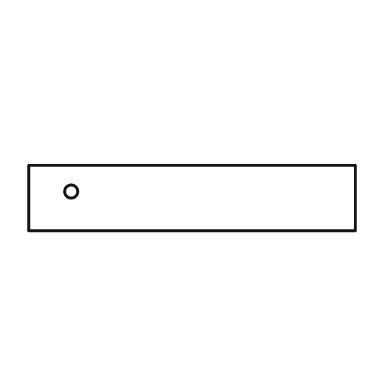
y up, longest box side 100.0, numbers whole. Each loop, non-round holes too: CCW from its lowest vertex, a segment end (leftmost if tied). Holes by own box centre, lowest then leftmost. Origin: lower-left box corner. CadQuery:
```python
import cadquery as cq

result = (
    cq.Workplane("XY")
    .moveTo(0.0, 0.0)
    .lineTo(100.0, 0.0)
    .lineTo(100.0, 20.0)
    .lineTo(0.0, 20.0)
    .close()
    .moveTo(13.0, 12.0)
    .circle(2.0)
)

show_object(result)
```